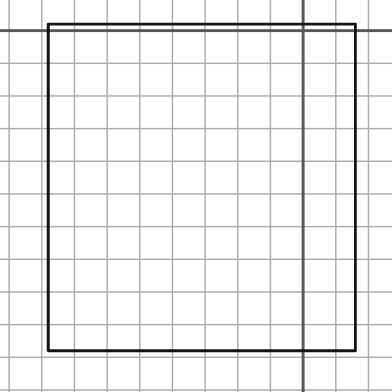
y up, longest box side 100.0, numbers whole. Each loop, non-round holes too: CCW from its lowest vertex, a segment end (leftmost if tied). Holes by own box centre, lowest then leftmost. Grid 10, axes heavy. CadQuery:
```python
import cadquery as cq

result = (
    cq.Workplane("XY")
    .moveTo(-78.0, -98.0)
    .lineTo(16.0, -98.0)
    .lineTo(16.0, 2.0)
    .lineTo(-78.0, 2.0)
    .close()
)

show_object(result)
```